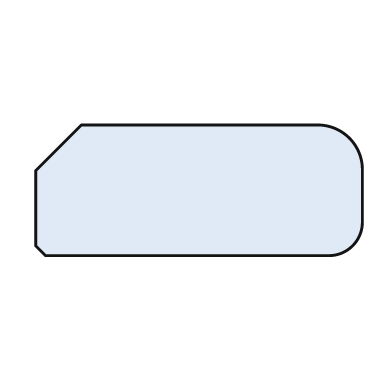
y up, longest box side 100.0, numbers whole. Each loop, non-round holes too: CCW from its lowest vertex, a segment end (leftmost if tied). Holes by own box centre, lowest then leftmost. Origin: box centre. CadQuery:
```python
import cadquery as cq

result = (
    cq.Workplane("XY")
    .moveTo(-47.0, -20.0)
    .lineTo(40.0, -20.0)
    .threePointArc((47.0, -17.0), (50.0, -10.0))
    .lineTo(50.0, 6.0)
    .threePointArc((46.0, 16.0), (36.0, 20.0))
    .lineTo(-36.0, 20.0)
    .lineTo(-50.0, 6.0)
    .lineTo(-50.0, -17.0)
    .close()
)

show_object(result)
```